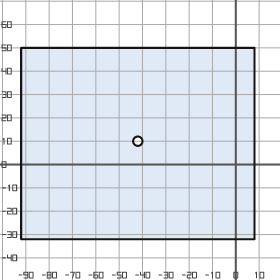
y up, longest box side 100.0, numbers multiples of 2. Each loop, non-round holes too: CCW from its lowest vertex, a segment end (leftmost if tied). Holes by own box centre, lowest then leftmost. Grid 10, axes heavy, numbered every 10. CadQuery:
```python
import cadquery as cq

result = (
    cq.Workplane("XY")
    .moveTo(-92.0, -32.0)
    .lineTo(8.0, -32.0)
    .lineTo(8.0, 50.0)
    .lineTo(-92.0, 50.0)
    .close()
    .moveTo(-42.0, 10.0)
    .circle(2.0)
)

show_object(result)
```